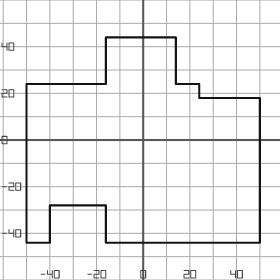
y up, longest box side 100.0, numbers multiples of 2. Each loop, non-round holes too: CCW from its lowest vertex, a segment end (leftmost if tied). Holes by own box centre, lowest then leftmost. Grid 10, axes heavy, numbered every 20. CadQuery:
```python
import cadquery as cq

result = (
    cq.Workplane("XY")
    .moveTo(-50.0, -44.0)
    .lineTo(-40.0, -44.0)
    .lineTo(-40.0, -28.0)
    .lineTo(-16.0, -28.0)
    .lineTo(-16.0, -44.0)
    .lineTo(50.0, -44.0)
    .lineTo(50.0, 18.0)
    .lineTo(24.0, 18.0)
    .lineTo(24.0, 24.0)
    .lineTo(14.0, 24.0)
    .lineTo(14.0, 44.0)
    .lineTo(-16.0, 44.0)
    .lineTo(-16.0, 24.0)
    .lineTo(-50.0, 24.0)
    .close()
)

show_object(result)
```